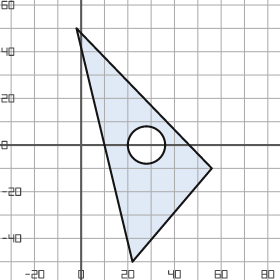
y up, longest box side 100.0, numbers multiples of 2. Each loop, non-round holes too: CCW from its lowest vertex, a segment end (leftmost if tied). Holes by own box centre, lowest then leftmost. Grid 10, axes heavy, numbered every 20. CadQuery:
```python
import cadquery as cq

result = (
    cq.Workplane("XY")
    .moveTo(22.0, -50.0)
    .lineTo(56.0, -10.0)
    .lineTo(-2.0, 50.0)
    .close()
    .moveTo(28.0, 0.0)
    .circle(8.0)
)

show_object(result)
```